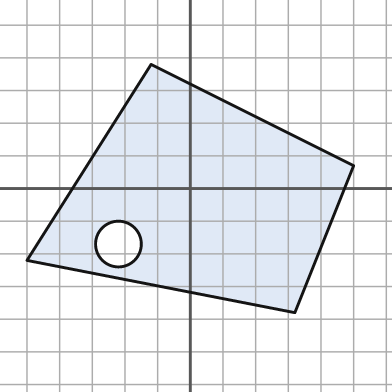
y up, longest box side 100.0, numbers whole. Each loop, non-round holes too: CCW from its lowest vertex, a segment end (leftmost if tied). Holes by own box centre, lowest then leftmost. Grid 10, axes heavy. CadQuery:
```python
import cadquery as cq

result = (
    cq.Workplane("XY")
    .moveTo(32.0, -38.0)
    .lineTo(50.0, 7.0)
    .lineTo(-12.0, 38.0)
    .lineTo(-50.0, -22.0)
    .close()
    .moveTo(-22.0, -17.0)
    .circle(7.0)
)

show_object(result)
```